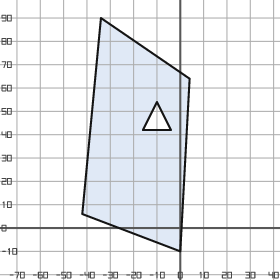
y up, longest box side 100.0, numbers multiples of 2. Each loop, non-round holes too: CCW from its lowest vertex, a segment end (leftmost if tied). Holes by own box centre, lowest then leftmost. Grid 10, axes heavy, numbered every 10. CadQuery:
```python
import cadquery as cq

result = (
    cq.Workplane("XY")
    .moveTo(0.0, -10.0)
    .lineTo(4.0, 64.0)
    .lineTo(-34.0, 90.0)
    .lineTo(-42.0, 6.0)
    .close()
    .moveTo(-16.0, 42.0)
    .lineTo(-4.0, 42.0)
    .lineTo(-10.0, 54.0)
    .close()
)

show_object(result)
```